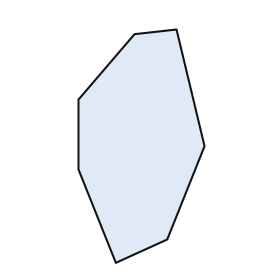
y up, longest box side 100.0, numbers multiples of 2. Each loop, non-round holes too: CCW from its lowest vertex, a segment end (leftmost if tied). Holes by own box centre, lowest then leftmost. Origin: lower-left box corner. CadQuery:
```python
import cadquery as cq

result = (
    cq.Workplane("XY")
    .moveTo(16.0, 0.0)
    .lineTo(38.0, 10.0)
    .lineTo(54.0, 50.0)
    .lineTo(42.0, 100.0)
    .lineTo(24.0, 98.0)
    .lineTo(0.0, 70.0)
    .lineTo(0.0, 40.0)
    .close()
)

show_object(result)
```